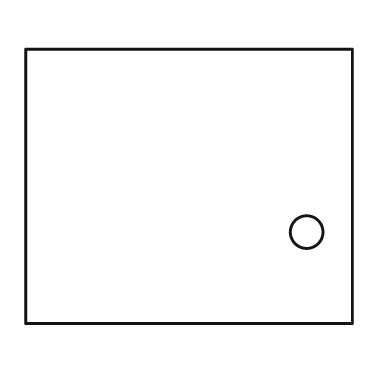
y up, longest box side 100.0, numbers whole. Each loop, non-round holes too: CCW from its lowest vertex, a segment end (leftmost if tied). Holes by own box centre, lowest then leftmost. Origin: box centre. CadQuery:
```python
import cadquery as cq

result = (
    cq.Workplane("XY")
    .moveTo(-50.0, -42.0)
    .lineTo(50.0, -42.0)
    .lineTo(50.0, 42.0)
    .lineTo(-50.0, 42.0)
    .close()
    .moveTo(36.0, -14.0)
    .circle(5.0)
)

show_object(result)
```